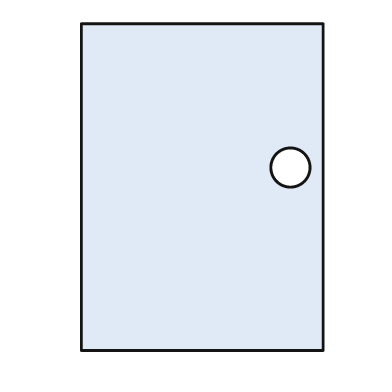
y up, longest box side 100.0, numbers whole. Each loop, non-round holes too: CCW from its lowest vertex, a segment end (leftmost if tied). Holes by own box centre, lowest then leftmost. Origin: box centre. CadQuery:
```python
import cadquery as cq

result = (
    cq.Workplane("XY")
    .moveTo(-37.0, -50.0)
    .lineTo(37.0, -50.0)
    .lineTo(37.0, 50.0)
    .lineTo(-37.0, 50.0)
    .close()
    .moveTo(27.0, 6.0)
    .circle(6.0)
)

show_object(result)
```